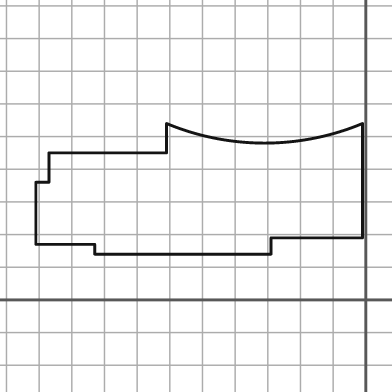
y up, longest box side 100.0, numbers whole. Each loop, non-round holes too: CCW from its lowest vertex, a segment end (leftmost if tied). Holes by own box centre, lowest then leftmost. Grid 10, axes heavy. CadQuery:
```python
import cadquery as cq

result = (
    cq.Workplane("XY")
    .moveTo(-83.0, 14.0)
    .lineTo(-29.0, 14.0)
    .lineTo(-29.0, 19.0)
    .lineTo(-1.0, 19.0)
    .lineTo(-1.0, 54.0)
    .threePointArc((-31.0, 48.0), (-61.0, 54.0))
    .lineTo(-61.0, 45.0)
    .lineTo(-97.0, 45.0)
    .lineTo(-97.0, 36.0)
    .lineTo(-101.0, 36.0)
    .lineTo(-101.0, 17.0)
    .lineTo(-83.0, 17.0)
    .close()
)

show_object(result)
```